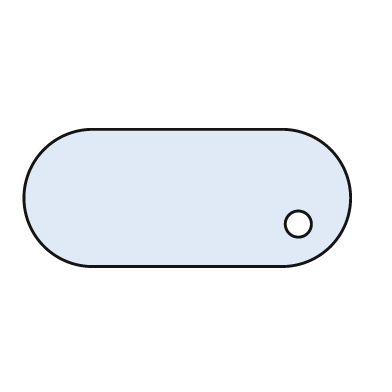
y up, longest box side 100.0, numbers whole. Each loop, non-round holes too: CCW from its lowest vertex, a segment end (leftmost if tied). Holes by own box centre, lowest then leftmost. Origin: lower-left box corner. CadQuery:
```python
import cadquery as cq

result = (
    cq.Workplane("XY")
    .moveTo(21.0, 0.0)
    .lineTo(79.0, 0.0)
    .threePointArc((100.0, 21.0), (79.0, 42.0))
    .lineTo(21.0, 42.0)
    .threePointArc((0.0, 21.0), (21.0, 0.0))
    .close()
    .moveTo(84.0, 13.0)
    .circle(4.0)
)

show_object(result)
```